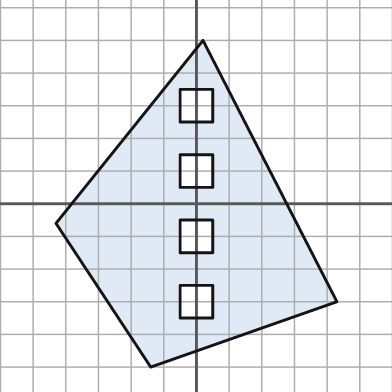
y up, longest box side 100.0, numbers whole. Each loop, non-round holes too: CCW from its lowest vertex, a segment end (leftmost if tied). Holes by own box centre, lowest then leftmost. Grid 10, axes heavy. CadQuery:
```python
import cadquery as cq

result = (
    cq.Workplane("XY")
    .moveTo(-14.0, -50.0)
    .lineTo(43.0, -30.0)
    .lineTo(2.0, 50.0)
    .lineTo(-43.0, -6.0)
    .close()
    .moveTo(-5.0, -35.0)
    .lineTo(5.0, -35.0)
    .lineTo(5.0, -25.0)
    .lineTo(-5.0, -25.0)
    .close()
    .moveTo(-5.0, -15.0)
    .lineTo(5.0, -15.0)
    .lineTo(5.0, -5.0)
    .lineTo(-5.0, -5.0)
    .close()
    .moveTo(-5.0, 5.0)
    .lineTo(5.0, 5.0)
    .lineTo(5.0, 15.0)
    .lineTo(-5.0, 15.0)
    .close()
    .moveTo(-5.0, 25.0)
    .lineTo(5.0, 25.0)
    .lineTo(5.0, 35.0)
    .lineTo(-5.0, 35.0)
    .close()
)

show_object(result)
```